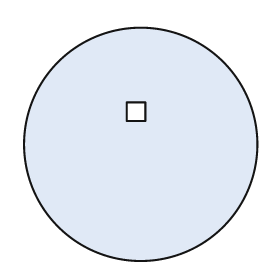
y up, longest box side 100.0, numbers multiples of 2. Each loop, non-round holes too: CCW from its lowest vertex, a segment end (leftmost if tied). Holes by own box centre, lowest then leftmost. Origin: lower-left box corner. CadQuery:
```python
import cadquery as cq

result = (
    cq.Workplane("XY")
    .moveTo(50.0, 50.0)
    .circle(50.0)
    .moveTo(44.0, 60.0)
    .lineTo(52.0, 60.0)
    .lineTo(52.0, 68.0)
    .lineTo(44.0, 68.0)
    .close()
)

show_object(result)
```